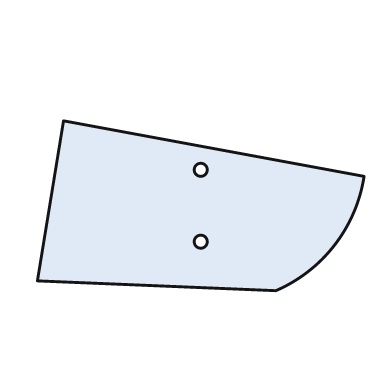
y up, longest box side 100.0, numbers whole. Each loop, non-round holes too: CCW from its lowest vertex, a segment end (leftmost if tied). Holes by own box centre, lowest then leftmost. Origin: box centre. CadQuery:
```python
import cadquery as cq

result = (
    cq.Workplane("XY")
    .moveTo(23.0, -26.0)
    .threePointArc((41.0, -12.0), (50.0, 9.0))
    .lineTo(-42.0, 26.0)
    .lineTo(-50.0, -23.0)
    .close()
    .moveTo(0.0, -11.0)
    .circle(2.0)
    .moveTo(0.0, 11.0)
    .circle(2.0)
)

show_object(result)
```